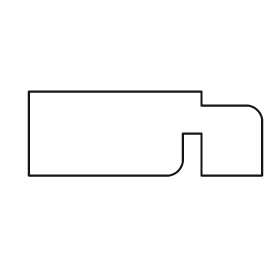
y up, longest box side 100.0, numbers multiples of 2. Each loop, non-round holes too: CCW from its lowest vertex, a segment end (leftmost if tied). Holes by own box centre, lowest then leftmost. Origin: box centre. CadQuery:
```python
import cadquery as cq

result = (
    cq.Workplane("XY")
    .moveTo(-50.0, -18.0)
    .lineTo(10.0, -18.0)
    .threePointArc((14.0, -16.0), (16.0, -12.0))
    .lineTo(16.0, 0.0)
    .lineTo(24.0, 0.0)
    .lineTo(24.0, -18.0)
    .lineTo(50.0, -18.0)
    .lineTo(50.0, 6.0)
    .threePointArc((48.0, 10.0), (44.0, 12.0))
    .lineTo(24.0, 12.0)
    .lineTo(24.0, 18.0)
    .lineTo(-50.0, 18.0)
    .close()
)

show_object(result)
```